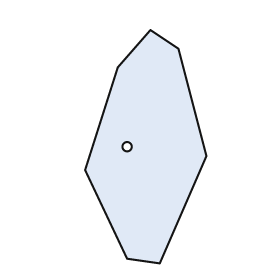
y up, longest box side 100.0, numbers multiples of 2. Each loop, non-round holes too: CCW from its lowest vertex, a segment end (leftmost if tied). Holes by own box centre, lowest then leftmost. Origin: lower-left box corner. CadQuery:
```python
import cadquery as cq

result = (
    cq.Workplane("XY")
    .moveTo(32.0, 0.0)
    .lineTo(52.0, 46.0)
    .lineTo(40.0, 92.0)
    .lineTo(28.0, 100.0)
    .lineTo(14.0, 84.0)
    .lineTo(0.0, 40.0)
    .lineTo(18.0, 2.0)
    .close()
    .moveTo(18.0, 50.0)
    .circle(2.0)
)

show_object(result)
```